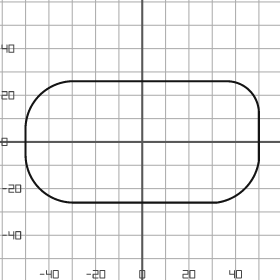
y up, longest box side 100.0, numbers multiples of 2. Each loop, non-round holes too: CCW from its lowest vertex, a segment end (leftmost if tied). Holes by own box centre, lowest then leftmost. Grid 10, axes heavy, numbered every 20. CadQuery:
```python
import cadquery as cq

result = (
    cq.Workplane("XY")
    .moveTo(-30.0, -26.0)
    .lineTo(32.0, -26.0)
    .threePointArc((44.0, -20.0), (50.0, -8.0))
    .lineTo(50.0, 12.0)
    .threePointArc((46.0, 22.0), (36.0, 26.0))
    .lineTo(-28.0, 26.0)
    .threePointArc((-44.0, 20.0), (-50.0, 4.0))
    .lineTo(-50.0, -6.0)
    .threePointArc((-44.0, -20.0), (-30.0, -26.0))
    .close()
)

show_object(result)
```